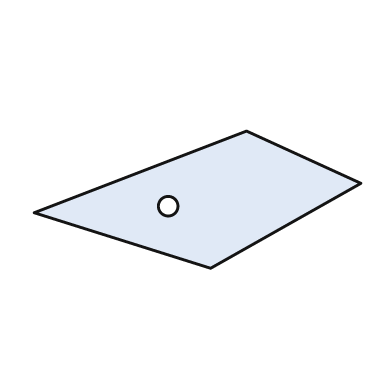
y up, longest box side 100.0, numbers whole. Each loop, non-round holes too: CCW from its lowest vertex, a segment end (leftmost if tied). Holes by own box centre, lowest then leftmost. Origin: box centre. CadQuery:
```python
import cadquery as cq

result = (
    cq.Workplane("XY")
    .moveTo(4.0, -21.0)
    .lineTo(50.0, 5.0)
    .lineTo(15.0, 21.0)
    .lineTo(-50.0, -4.0)
    .close()
    .moveTo(-9.0, -2.0)
    .circle(3.0)
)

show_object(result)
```